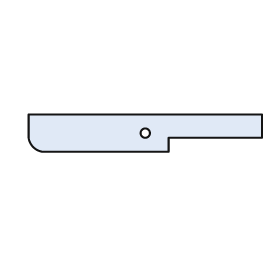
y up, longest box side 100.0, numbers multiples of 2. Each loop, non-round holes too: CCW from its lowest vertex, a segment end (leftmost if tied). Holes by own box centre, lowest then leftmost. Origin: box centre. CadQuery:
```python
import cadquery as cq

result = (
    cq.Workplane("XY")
    .moveTo(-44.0, -8.0)
    .lineTo(10.0, -8.0)
    .lineTo(10.0, -2.0)
    .lineTo(50.0, -2.0)
    .lineTo(50.0, 8.0)
    .lineTo(-50.0, 8.0)
    .lineTo(-50.0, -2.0)
    .threePointArc((-48.0, -6.0), (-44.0, -8.0))
    .close()
    .moveTo(0.0, 0.0)
    .circle(2.0)
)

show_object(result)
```